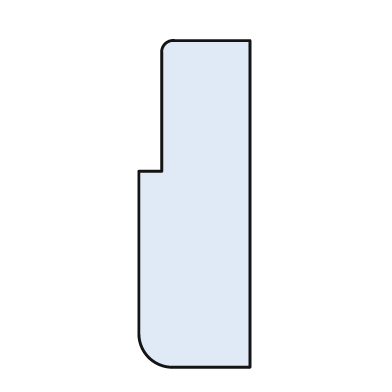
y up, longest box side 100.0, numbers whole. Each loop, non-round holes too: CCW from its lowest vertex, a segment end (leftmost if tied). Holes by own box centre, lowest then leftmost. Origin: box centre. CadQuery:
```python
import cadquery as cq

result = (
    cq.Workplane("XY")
    .moveTo(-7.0, -50.0)
    .lineTo(17.0, -50.0)
    .lineTo(17.0, 50.0)
    .lineTo(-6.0, 50.0)
    .threePointArc((-9.0, 49.0), (-10.0, 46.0))
    .lineTo(-10.0, 10.0)
    .lineTo(-17.0, 10.0)
    .lineTo(-17.0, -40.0)
    .threePointArc((-14.0, -47.0), (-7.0, -50.0))
    .close()
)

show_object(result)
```